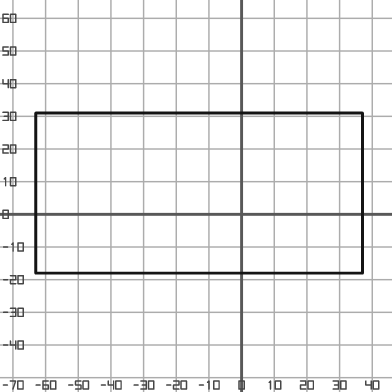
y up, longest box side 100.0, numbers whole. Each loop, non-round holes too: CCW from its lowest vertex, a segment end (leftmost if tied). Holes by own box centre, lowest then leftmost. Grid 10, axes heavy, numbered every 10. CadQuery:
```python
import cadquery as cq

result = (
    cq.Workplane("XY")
    .moveTo(-63.0, -18.0)
    .lineTo(37.0, -18.0)
    .lineTo(37.0, 31.0)
    .lineTo(-63.0, 31.0)
    .close()
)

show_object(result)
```